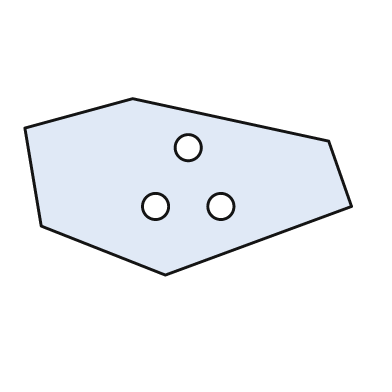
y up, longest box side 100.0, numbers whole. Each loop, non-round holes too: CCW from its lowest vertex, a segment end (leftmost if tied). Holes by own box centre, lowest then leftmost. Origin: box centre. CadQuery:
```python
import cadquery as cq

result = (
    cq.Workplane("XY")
    .moveTo(-7.0, -27.0)
    .lineTo(50.0, -6.0)
    .lineTo(43.0, 14.0)
    .lineTo(-17.0, 27.0)
    .lineTo(-50.0, 18.0)
    .lineTo(-45.0, -12.0)
    .close()
    .moveTo(-10.0, -6.0)
    .circle(4.0)
    .moveTo(10.0, -6.0)
    .circle(4.0)
    .moveTo(0.0, 12.0)
    .circle(4.0)
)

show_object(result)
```